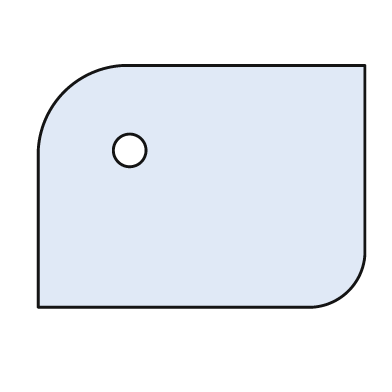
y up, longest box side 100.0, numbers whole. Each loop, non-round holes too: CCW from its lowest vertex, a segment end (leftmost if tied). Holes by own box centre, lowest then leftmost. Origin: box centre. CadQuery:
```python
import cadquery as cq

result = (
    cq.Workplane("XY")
    .moveTo(-50.0, -37.0)
    .lineTo(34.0, -37.0)
    .threePointArc((45.0, -32.0), (50.0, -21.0))
    .lineTo(50.0, 37.0)
    .lineTo(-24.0, 37.0)
    .threePointArc((-42.0, 29.0), (-50.0, 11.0))
    .close()
    .moveTo(-22.0, 11.0)
    .circle(5.0)
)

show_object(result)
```